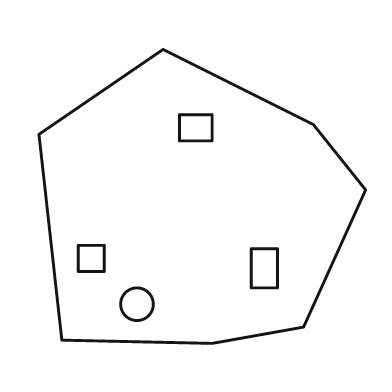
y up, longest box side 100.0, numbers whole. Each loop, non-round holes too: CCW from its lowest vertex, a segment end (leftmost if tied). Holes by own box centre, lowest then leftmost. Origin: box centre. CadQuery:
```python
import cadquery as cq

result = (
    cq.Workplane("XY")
    .moveTo(3.0, -45.0)
    .lineTo(31.0, -40.0)
    .lineTo(50.0, 2.0)
    .lineTo(34.0, 22.0)
    .lineTo(-12.0, 45.0)
    .lineTo(-50.0, 19.0)
    .lineTo(-43.0, -44.0)
    .close()
    .moveTo(-20.0, -33.0)
    .circle(5.0)
    .moveTo(15.0, -28.0)
    .lineTo(23.0, -28.0)
    .lineTo(23.0, -16.0)
    .lineTo(15.0, -16.0)
    .close()
    .moveTo(-38.0, -23.0)
    .lineTo(-30.0, -23.0)
    .lineTo(-30.0, -15.0)
    .lineTo(-38.0, -15.0)
    .close()
    .moveTo(-7.0, 17.0)
    .lineTo(3.0, 17.0)
    .lineTo(3.0, 25.0)
    .lineTo(-7.0, 25.0)
    .close()
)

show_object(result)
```